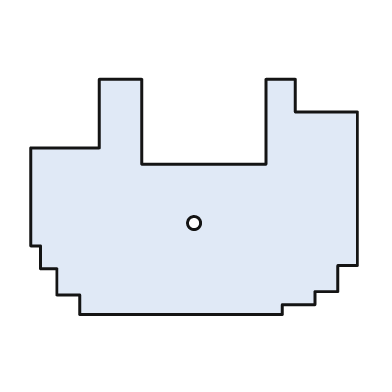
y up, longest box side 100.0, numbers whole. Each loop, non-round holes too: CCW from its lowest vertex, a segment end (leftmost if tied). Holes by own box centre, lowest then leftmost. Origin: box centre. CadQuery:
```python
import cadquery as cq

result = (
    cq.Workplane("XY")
    .moveTo(-35.0, -36.0)
    .lineTo(27.0, -36.0)
    .lineTo(27.0, -33.0)
    .lineTo(37.0, -33.0)
    .lineTo(37.0, -29.0)
    .lineTo(44.0, -29.0)
    .lineTo(44.0, -21.0)
    .lineTo(50.0, -21.0)
    .lineTo(50.0, 26.0)
    .lineTo(31.0, 26.0)
    .lineTo(31.0, 36.0)
    .lineTo(22.0, 36.0)
    .lineTo(22.0, 10.0)
    .lineTo(-16.0, 10.0)
    .lineTo(-16.0, 36.0)
    .lineTo(-29.0, 36.0)
    .lineTo(-29.0, 15.0)
    .lineTo(-50.0, 15.0)
    .lineTo(-50.0, -15.0)
    .lineTo(-47.0, -15.0)
    .lineTo(-47.0, -22.0)
    .lineTo(-42.0, -22.0)
    .lineTo(-42.0, -30.0)
    .lineTo(-35.0, -30.0)
    .close()
    .moveTo(0.0, -8.0)
    .circle(2.0)
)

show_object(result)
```